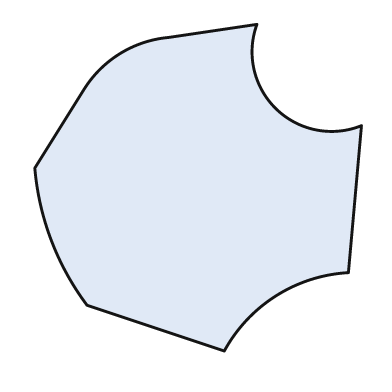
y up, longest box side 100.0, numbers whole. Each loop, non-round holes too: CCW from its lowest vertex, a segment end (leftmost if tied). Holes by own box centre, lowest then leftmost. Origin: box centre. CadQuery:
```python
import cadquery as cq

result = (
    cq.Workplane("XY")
    .moveTo(8.0, -50.0)
    .threePointArc((24.0, -33.0), (46.0, -26.0))
    .lineTo(50.0, 19.0)
    .threePointArc((24.0, 24.0), (18.0, 50.0))
    .lineTo(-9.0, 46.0)
    .threePointArc((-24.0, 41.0), (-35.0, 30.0))
    .lineTo(-50.0, 6.0)
    .threePointArc((-45.0, -16.0), (-34.0, -36.0))
    .close()
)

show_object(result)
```